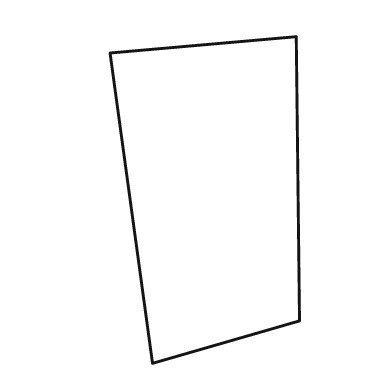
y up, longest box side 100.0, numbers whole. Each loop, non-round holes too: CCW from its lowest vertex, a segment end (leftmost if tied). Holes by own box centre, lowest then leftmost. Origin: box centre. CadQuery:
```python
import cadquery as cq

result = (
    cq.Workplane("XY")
    .moveTo(-16.0, -50.0)
    .lineTo(29.0, -37.0)
    .lineTo(28.0, 50.0)
    .lineTo(-29.0, 45.0)
    .close()
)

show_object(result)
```